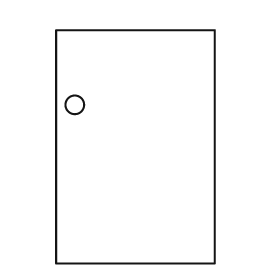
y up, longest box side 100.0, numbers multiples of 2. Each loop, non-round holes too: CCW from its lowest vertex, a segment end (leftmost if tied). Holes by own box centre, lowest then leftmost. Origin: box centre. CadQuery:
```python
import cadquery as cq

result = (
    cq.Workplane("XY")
    .moveTo(-34.0, -50.0)
    .lineTo(34.0, -50.0)
    .lineTo(34.0, 50.0)
    .lineTo(-34.0, 50.0)
    .close()
    .moveTo(-26.0, 18.0)
    .circle(4.0)
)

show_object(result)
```